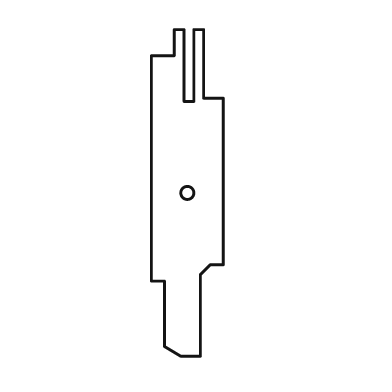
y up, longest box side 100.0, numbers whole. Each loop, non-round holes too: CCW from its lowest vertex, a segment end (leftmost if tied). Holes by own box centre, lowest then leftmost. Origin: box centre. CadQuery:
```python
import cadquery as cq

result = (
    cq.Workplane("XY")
    .moveTo(-2.0, -50.0)
    .lineTo(4.0, -50.0)
    .lineTo(4.0, -25.0)
    .lineTo(7.0, -22.0)
    .lineTo(11.0, -22.0)
    .lineTo(11.0, 29.0)
    .lineTo(5.0, 29.0)
    .lineTo(5.0, 50.0)
    .lineTo(2.0, 50.0)
    .lineTo(2.0, 28.0)
    .lineTo(-1.0, 28.0)
    .lineTo(-1.0, 50.0)
    .lineTo(-4.0, 50.0)
    .lineTo(-4.0, 42.0)
    .lineTo(-11.0, 42.0)
    .lineTo(-11.0, -27.0)
    .lineTo(-7.0, -27.0)
    .lineTo(-7.0, -47.0)
    .close()
    .moveTo(0.0, 0.0)
    .circle(2.0)
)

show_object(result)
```